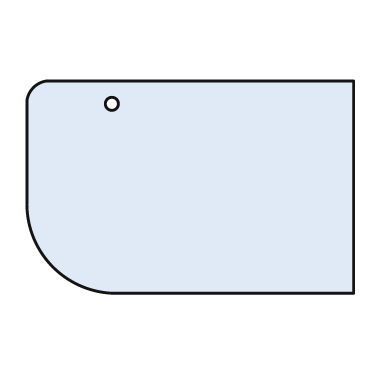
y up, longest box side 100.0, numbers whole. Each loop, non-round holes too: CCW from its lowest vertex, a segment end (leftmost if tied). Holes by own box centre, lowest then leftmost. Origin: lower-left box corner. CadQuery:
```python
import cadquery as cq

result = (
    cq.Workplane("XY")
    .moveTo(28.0, 0.0)
    .lineTo(100.0, 0.0)
    .lineTo(100.0, 65.0)
    .lineTo(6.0, 65.0)
    .threePointArc((2.0, 63.0), (0.0, 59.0))
    .lineTo(0.0, 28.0)
    .threePointArc((8.0, 8.0), (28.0, 0.0))
    .close()
    .moveTo(26.0, 58.0)
    .circle(2.0)
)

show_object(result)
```